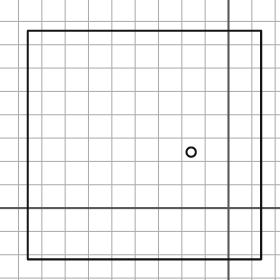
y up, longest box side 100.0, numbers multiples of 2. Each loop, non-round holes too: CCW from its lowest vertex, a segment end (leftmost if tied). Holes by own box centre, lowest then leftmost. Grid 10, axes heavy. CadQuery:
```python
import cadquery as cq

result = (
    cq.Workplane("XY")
    .moveTo(-86.0, -22.0)
    .lineTo(14.0, -22.0)
    .lineTo(14.0, 76.0)
    .lineTo(-86.0, 76.0)
    .close()
    .moveTo(-16.0, 24.0)
    .circle(2.0)
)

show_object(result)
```